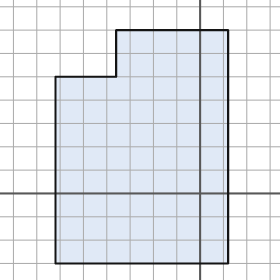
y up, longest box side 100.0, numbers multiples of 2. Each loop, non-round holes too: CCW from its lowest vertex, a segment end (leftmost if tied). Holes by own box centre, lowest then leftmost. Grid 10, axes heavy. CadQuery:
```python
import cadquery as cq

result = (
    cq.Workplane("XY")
    .moveTo(-62.0, -30.0)
    .lineTo(12.0, -30.0)
    .lineTo(12.0, 70.0)
    .lineTo(-36.0, 70.0)
    .lineTo(-36.0, 50.0)
    .lineTo(-62.0, 50.0)
    .close()
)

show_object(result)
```